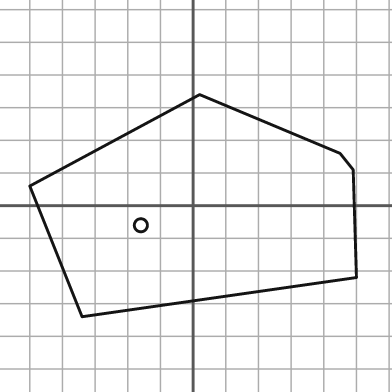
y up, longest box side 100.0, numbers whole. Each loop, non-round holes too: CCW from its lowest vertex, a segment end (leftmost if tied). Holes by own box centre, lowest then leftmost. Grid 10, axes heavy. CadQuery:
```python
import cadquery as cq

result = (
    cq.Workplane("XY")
    .moveTo(-34.0, -34.0)
    .lineTo(50.0, -22.0)
    .lineTo(49.0, 11.0)
    .lineTo(45.0, 16.0)
    .lineTo(2.0, 34.0)
    .lineTo(-50.0, 6.0)
    .close()
    .moveTo(-16.0, -6.0)
    .circle(2.0)
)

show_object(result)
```